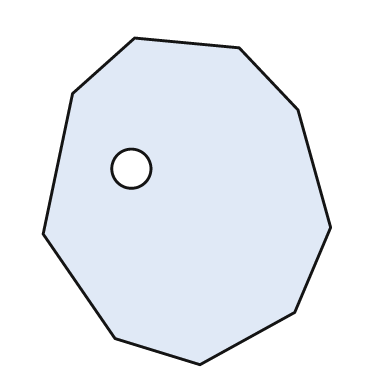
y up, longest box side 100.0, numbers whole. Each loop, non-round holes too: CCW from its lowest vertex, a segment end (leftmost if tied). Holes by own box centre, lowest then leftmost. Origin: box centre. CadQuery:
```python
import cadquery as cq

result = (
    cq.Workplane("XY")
    .moveTo(4.0, -50.0)
    .lineTo(33.0, -34.0)
    .lineTo(44.0, -8.0)
    .lineTo(34.0, 28.0)
    .lineTo(16.0, 47.0)
    .lineTo(-16.0, 50.0)
    .lineTo(-35.0, 33.0)
    .lineTo(-44.0, -10.0)
    .lineTo(-22.0, -42.0)
    .close()
    .moveTo(-17.0, 10.0)
    .circle(6.0)
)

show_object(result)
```